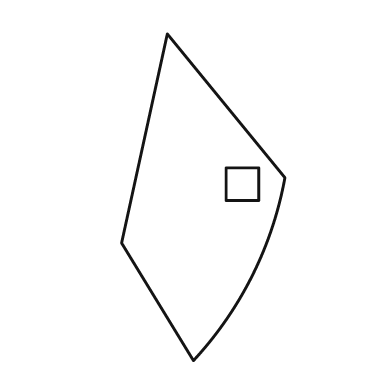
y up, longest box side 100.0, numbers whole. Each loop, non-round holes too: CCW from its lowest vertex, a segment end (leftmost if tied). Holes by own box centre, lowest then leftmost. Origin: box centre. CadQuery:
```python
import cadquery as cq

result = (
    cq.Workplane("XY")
    .moveTo(-3.0, -50.0)
    .threePointArc((15.0, -24.0), (25.0, 6.0))
    .lineTo(-11.0, 50.0)
    .lineTo(-25.0, -14.0)
    .close()
    .moveTo(7.0, -1.0)
    .lineTo(17.0, -1.0)
    .lineTo(17.0, 9.0)
    .lineTo(7.0, 9.0)
    .close()
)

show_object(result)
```